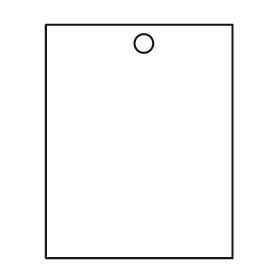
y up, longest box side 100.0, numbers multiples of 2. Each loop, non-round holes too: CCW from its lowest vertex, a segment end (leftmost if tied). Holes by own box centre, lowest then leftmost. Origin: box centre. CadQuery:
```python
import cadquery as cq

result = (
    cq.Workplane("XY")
    .moveTo(-40.0, -50.0)
    .lineTo(40.0, -50.0)
    .lineTo(40.0, 50.0)
    .lineTo(-40.0, 50.0)
    .close()
    .moveTo(2.0, 42.0)
    .circle(4.0)
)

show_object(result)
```